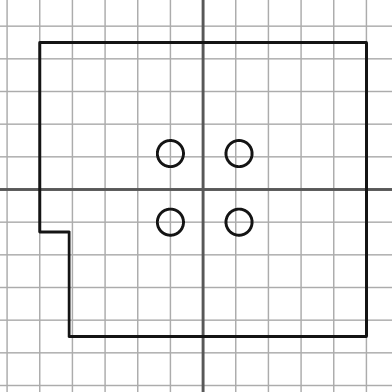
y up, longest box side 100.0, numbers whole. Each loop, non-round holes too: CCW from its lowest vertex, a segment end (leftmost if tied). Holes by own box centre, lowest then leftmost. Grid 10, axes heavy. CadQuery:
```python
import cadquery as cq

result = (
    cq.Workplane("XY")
    .moveTo(-41.0, -45.0)
    .lineTo(50.0, -45.0)
    .lineTo(50.0, 45.0)
    .lineTo(-50.0, 45.0)
    .lineTo(-50.0, -13.0)
    .lineTo(-41.0, -13.0)
    .close()
    .moveTo(-10.0, -10.0)
    .circle(4.0)
    .moveTo(11.0, -10.0)
    .circle(4.0)
    .moveTo(-10.0, 11.0)
    .circle(4.0)
    .moveTo(11.0, 11.0)
    .circle(4.0)
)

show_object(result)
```